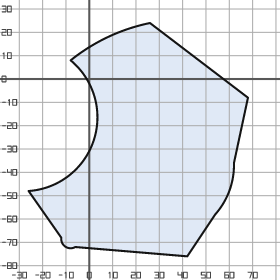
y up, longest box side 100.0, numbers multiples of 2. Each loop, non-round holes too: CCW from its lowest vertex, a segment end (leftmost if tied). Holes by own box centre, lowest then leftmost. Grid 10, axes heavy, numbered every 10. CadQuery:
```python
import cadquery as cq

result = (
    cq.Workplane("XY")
    .moveTo(42.0, -76.0)
    .lineTo(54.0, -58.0)
    .threePointArc((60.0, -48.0), (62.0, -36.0))
    .lineTo(68.0, -8.0)
    .lineTo(26.0, 24.0)
    .threePointArc((8.0, 18.0), (-8.0, 8.0))
    .threePointArc((2.0, -26.0), (-26.0, -48.0))
    .lineTo(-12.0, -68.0)
    .threePointArc((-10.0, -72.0), (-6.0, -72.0))
    .close()
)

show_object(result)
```